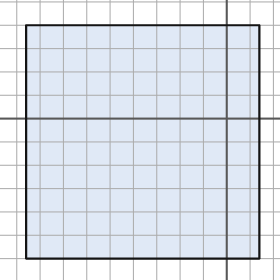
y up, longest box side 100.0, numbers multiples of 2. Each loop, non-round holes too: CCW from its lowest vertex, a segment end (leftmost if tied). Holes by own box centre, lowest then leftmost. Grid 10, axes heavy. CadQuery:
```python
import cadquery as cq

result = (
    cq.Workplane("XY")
    .moveTo(-86.0, -60.0)
    .lineTo(14.0, -60.0)
    .lineTo(14.0, 40.0)
    .lineTo(-86.0, 40.0)
    .close()
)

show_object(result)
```